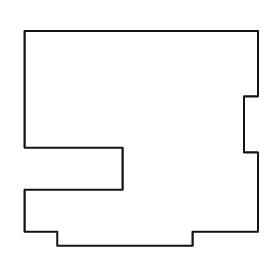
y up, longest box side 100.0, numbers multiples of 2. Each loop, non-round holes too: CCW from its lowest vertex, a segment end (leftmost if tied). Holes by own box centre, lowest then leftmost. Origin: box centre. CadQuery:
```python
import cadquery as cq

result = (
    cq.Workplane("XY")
    .moveTo(-36.0, -46.0)
    .lineTo(22.0, -46.0)
    .lineTo(22.0, -40.0)
    .lineTo(50.0, -40.0)
    .lineTo(50.0, -6.0)
    .lineTo(44.0, -6.0)
    .lineTo(44.0, 18.0)
    .lineTo(50.0, 18.0)
    .lineTo(50.0, 46.0)
    .lineTo(-50.0, 46.0)
    .lineTo(-50.0, -4.0)
    .lineTo(-8.0, -4.0)
    .lineTo(-8.0, -22.0)
    .lineTo(-50.0, -22.0)
    .lineTo(-50.0, -40.0)
    .lineTo(-36.0, -40.0)
    .close()
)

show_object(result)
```